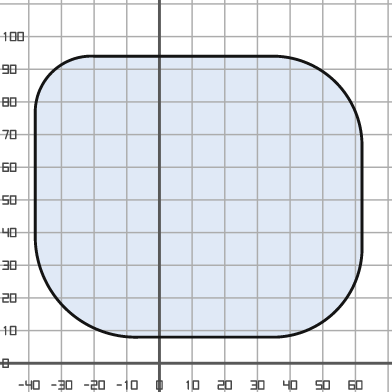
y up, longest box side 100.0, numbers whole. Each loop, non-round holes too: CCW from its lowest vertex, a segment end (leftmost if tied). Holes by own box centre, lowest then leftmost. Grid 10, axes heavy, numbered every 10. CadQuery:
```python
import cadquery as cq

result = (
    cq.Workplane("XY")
    .moveTo(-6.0, 8.0)
    .lineTo(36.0, 8.0)
    .threePointArc((54.0, 16.0), (62.0, 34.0))
    .lineTo(62.0, 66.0)
    .threePointArc((54.0, 86.0), (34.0, 94.0))
    .lineTo(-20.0, 94.0)
    .threePointArc((-33.0, 89.0), (-38.0, 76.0))
    .lineTo(-38.0, 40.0)
    .threePointArc((-29.0, 17.0), (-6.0, 8.0))
    .close()
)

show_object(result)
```